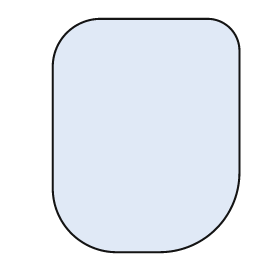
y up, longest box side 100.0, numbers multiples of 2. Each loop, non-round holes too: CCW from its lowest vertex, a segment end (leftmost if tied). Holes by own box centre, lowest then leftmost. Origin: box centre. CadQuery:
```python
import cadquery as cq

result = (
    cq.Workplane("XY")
    .moveTo(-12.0, -50.0)
    .lineTo(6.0, -50.0)
    .threePointArc((30.0, -40.0), (40.0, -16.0))
    .lineTo(40.0, 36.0)
    .threePointArc((36.0, 46.0), (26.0, 50.0))
    .lineTo(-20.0, 50.0)
    .threePointArc((-34.0, 44.0), (-40.0, 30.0))
    .lineTo(-40.0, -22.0)
    .threePointArc((-32.0, -42.0), (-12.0, -50.0))
    .close()
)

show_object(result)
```